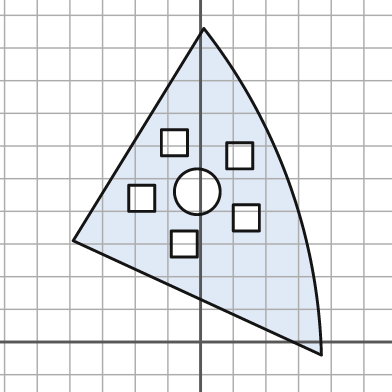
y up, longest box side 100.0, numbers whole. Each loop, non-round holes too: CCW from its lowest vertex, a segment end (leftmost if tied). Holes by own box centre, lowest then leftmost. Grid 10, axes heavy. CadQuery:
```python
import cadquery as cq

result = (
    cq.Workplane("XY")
    .moveTo(37.0, -4.0)
    .threePointArc((27.0, 49.0), (1.0, 96.0))
    .lineTo(-39.0, 31.0)
    .close()
    .moveTo(-9.0, 26.0)
    .lineTo(-1.0, 26.0)
    .lineTo(-1.0, 34.0)
    .lineTo(-9.0, 34.0)
    .close()
    .moveTo(10.0, 34.0)
    .lineTo(18.0, 34.0)
    .lineTo(18.0, 42.0)
    .lineTo(10.0, 42.0)
    .close()
    .moveTo(-22.0, 40.0)
    .lineTo(-14.0, 40.0)
    .lineTo(-14.0, 48.0)
    .lineTo(-22.0, 48.0)
    .close()
    .moveTo(-1.0, 46.0)
    .circle(7.0)
    .moveTo(8.0, 53.0)
    .lineTo(16.0, 53.0)
    .lineTo(16.0, 61.0)
    .lineTo(8.0, 61.0)
    .close()
    .moveTo(-12.0, 57.0)
    .lineTo(-4.0, 57.0)
    .lineTo(-4.0, 65.0)
    .lineTo(-12.0, 65.0)
    .close()
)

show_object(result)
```